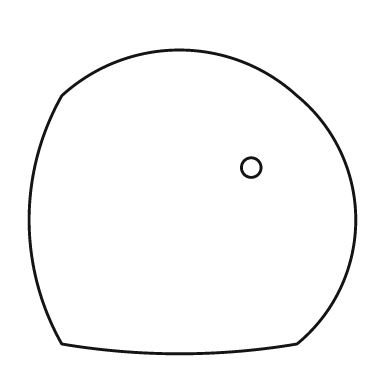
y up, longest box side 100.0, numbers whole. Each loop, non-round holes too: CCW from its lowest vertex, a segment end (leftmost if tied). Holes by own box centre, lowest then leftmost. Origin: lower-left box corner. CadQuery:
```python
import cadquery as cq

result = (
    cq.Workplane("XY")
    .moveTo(10.0, 3.0)
    .threePointArc((46.0, 0.0), (82.0, 3.0))
    .threePointArc((100.0, 41.0), (82.0, 79.0))
    .threePointArc((46.0, 93.0), (10.0, 79.0))
    .threePointArc((0.0, 41.0), (10.0, 3.0))
    .close()
    .moveTo(68.0, 57.0)
    .circle(3.0)
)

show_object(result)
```